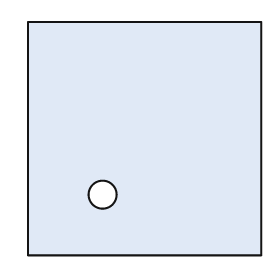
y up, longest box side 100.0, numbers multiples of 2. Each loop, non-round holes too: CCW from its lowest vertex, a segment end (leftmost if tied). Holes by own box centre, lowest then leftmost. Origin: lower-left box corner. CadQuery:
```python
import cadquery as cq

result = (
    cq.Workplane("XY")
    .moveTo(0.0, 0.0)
    .lineTo(100.0, 0.0)
    .lineTo(100.0, 100.0)
    .lineTo(0.0, 100.0)
    .close()
    .moveTo(32.0, 26.0)
    .circle(6.0)
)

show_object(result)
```